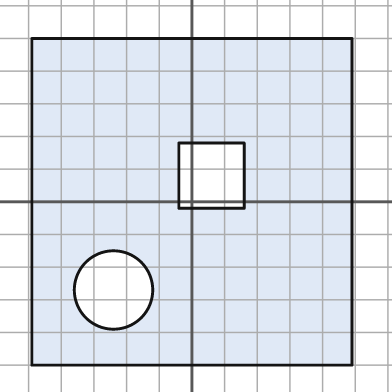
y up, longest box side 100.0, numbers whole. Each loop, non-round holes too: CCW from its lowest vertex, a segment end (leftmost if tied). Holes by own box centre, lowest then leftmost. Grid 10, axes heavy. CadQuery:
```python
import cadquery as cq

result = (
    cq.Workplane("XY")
    .moveTo(-49.0, -50.0)
    .lineTo(49.0, -50.0)
    .lineTo(49.0, 50.0)
    .lineTo(-49.0, 50.0)
    .close()
    .moveTo(-24.0, -27.0)
    .circle(12.0)
    .moveTo(-4.0, -2.0)
    .lineTo(16.0, -2.0)
    .lineTo(16.0, 18.0)
    .lineTo(-4.0, 18.0)
    .close()
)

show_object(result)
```